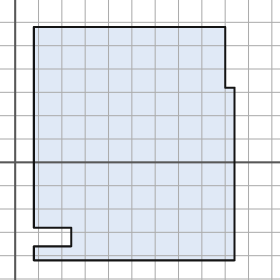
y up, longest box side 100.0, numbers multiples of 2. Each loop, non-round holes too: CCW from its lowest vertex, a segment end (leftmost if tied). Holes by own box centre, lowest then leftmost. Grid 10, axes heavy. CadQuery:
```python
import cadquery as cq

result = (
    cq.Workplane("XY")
    .moveTo(8.0, -42.0)
    .lineTo(94.0, -42.0)
    .lineTo(94.0, 32.0)
    .lineTo(90.0, 32.0)
    .lineTo(90.0, 58.0)
    .lineTo(8.0, 58.0)
    .lineTo(8.0, -28.0)
    .lineTo(24.0, -28.0)
    .lineTo(24.0, -36.0)
    .lineTo(8.0, -36.0)
    .close()
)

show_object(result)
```